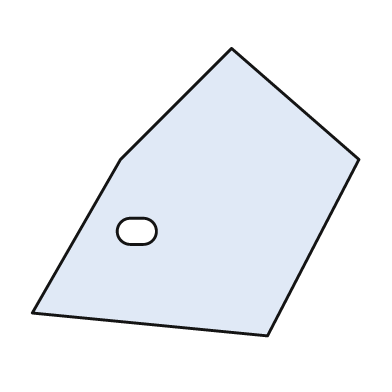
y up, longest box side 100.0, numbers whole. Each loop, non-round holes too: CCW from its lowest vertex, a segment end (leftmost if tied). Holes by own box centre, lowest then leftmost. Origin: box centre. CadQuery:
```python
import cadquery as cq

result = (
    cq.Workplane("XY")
    .moveTo(22.0, -44.0)
    .lineTo(50.0, 10.0)
    .lineTo(11.0, 44.0)
    .lineTo(-23.0, 10.0)
    .lineTo(-50.0, -37.0)
    .close()
    .moveTo(-20.0, -16.0)
    .lineTo(-16.0, -16.0)
    .threePointArc((-12.0, -12.0), (-16.0, -8.0))
    .lineTo(-20.0, -8.0)
    .threePointArc((-24.0, -12.0), (-20.0, -16.0))
    .close()
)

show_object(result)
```